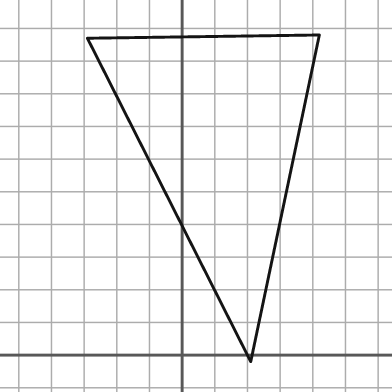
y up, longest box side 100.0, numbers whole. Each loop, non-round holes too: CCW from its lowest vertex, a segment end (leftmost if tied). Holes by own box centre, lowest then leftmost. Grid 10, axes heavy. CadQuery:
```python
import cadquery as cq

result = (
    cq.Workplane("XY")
    .moveTo(21.0, -2.0)
    .lineTo(42.0, 98.0)
    .lineTo(-29.0, 97.0)
    .close()
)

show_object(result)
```